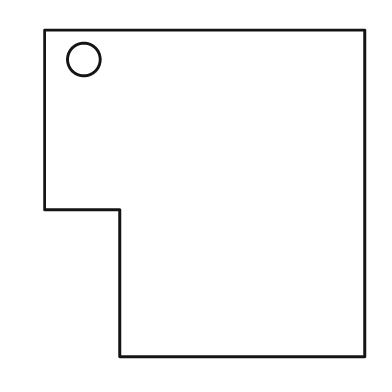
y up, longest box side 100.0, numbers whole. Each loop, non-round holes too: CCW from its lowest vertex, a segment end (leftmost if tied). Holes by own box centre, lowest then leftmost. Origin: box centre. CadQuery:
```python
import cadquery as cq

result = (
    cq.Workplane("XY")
    .moveTo(-26.0, -50.0)
    .lineTo(49.0, -50.0)
    .lineTo(49.0, 50.0)
    .lineTo(-49.0, 50.0)
    .lineTo(-49.0, -5.0)
    .lineTo(-26.0, -5.0)
    .close()
    .moveTo(-37.0, 41.0)
    .circle(5.0)
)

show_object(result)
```